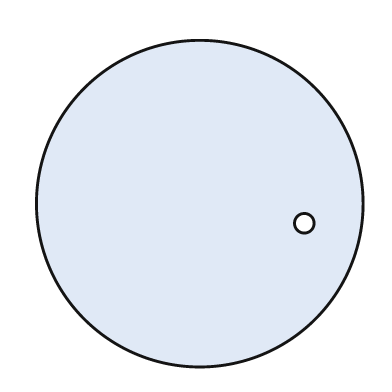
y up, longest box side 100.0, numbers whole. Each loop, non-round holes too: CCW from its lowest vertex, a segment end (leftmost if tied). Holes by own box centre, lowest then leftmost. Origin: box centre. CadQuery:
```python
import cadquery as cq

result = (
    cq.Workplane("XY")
    .moveTo(0.0, 0.0)
    .circle(50.0)
    .moveTo(32.0, -6.0)
    .circle(3.0)
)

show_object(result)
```